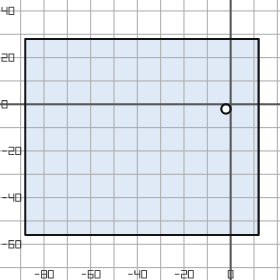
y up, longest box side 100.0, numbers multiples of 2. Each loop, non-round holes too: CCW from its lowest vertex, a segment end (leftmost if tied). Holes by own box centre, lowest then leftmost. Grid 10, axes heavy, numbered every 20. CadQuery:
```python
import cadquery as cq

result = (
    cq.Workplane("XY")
    .moveTo(-88.0, -56.0)
    .lineTo(12.0, -56.0)
    .lineTo(12.0, 28.0)
    .lineTo(-88.0, 28.0)
    .close()
    .moveTo(-2.0, -2.0)
    .circle(2.0)
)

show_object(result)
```